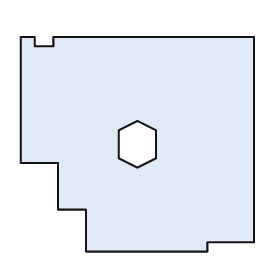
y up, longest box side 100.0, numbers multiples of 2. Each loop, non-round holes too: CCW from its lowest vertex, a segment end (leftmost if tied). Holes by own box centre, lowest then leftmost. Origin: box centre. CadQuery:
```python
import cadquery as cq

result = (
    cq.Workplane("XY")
    .moveTo(-22.0, -46.0)
    .lineTo(30.0, -46.0)
    .lineTo(30.0, -42.0)
    .lineTo(50.0, -42.0)
    .lineTo(50.0, 46.0)
    .lineTo(-36.0, 46.0)
    .lineTo(-36.0, 42.0)
    .lineTo(-44.0, 42.0)
    .lineTo(-44.0, 46.0)
    .lineTo(-50.0, 46.0)
    .lineTo(-50.0, -8.0)
    .lineTo(-34.0, -8.0)
    .lineTo(-34.0, -28.0)
    .lineTo(-22.0, -28.0)
    .close()
    .moveTo(0.0, -10.0)
    .lineTo(8.0, -6.0)
    .lineTo(8.0, 6.0)
    .lineTo(0.0, 10.0)
    .lineTo(-8.0, 6.0)
    .lineTo(-8.0, -6.0)
    .close()
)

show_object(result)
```